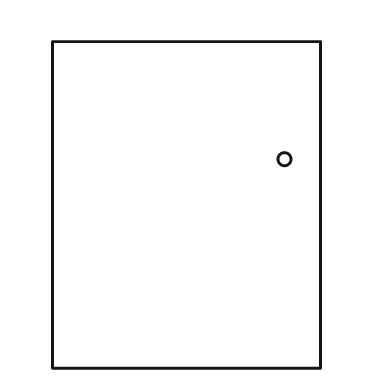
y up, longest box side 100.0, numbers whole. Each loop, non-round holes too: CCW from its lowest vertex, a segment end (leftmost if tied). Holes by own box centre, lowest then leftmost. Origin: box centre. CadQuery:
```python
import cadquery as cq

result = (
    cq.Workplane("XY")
    .moveTo(-41.0, -50.0)
    .lineTo(41.0, -50.0)
    .lineTo(41.0, 50.0)
    .lineTo(-41.0, 50.0)
    .close()
    .moveTo(30.0, 14.0)
    .circle(2.0)
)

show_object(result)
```